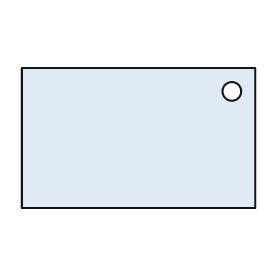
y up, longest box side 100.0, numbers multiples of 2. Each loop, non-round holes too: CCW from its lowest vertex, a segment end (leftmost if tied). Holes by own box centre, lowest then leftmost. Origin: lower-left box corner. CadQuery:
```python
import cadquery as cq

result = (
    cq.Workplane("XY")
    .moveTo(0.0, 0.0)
    .lineTo(100.0, 0.0)
    .lineTo(100.0, 60.0)
    .lineTo(0.0, 60.0)
    .close()
    .moveTo(90.0, 50.0)
    .circle(4.0)
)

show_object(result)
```